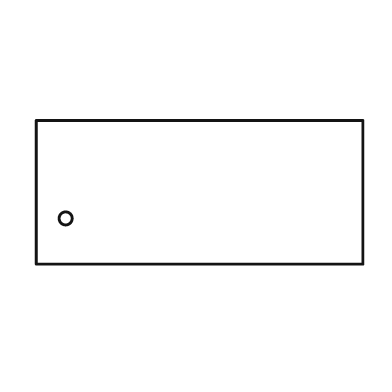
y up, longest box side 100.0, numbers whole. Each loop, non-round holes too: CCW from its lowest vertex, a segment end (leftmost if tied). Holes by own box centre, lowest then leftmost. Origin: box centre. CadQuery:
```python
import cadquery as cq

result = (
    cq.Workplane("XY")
    .moveTo(-50.0, -22.0)
    .lineTo(50.0, -22.0)
    .lineTo(50.0, 22.0)
    .lineTo(-50.0, 22.0)
    .close()
    .moveTo(-41.0, -8.0)
    .circle(2.0)
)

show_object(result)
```